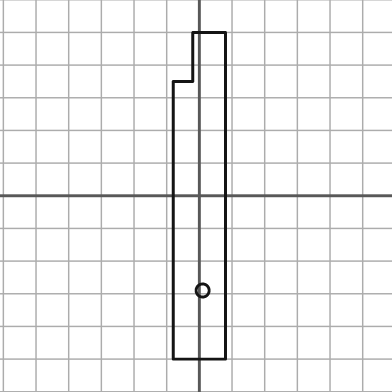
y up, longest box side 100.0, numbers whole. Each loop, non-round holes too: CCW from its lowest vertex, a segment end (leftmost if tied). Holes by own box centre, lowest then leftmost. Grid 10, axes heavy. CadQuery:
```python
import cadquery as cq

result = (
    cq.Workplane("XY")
    .moveTo(-8.0, -50.0)
    .lineTo(8.0, -50.0)
    .lineTo(8.0, 50.0)
    .lineTo(-2.0, 50.0)
    .lineTo(-2.0, 35.0)
    .lineTo(-8.0, 35.0)
    .close()
    .moveTo(1.0, -29.0)
    .circle(2.0)
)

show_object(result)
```